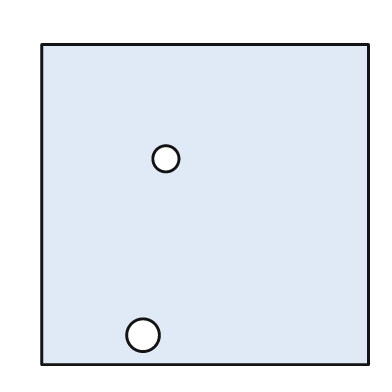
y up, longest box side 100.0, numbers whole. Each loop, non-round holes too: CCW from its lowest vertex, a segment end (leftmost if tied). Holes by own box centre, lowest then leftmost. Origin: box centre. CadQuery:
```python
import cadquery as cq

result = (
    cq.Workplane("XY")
    .moveTo(-50.0, -49.0)
    .lineTo(50.0, -49.0)
    .lineTo(50.0, 49.0)
    .lineTo(-50.0, 49.0)
    .close()
    .moveTo(-19.0, -40.0)
    .circle(5.0)
    .moveTo(-12.0, 14.0)
    .circle(4.0)
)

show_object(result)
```